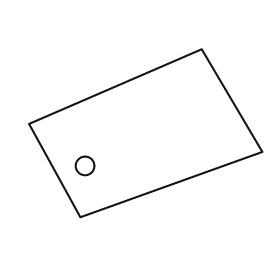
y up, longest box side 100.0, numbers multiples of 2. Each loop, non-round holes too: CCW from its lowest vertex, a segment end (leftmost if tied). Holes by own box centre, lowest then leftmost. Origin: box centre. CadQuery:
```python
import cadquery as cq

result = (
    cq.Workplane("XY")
    .moveTo(-28.0, -36.0)
    .lineTo(50.0, -8.0)
    .lineTo(24.0, 36.0)
    .lineTo(-50.0, 4.0)
    .close()
    .moveTo(-26.0, -14.0)
    .circle(4.0)
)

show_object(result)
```